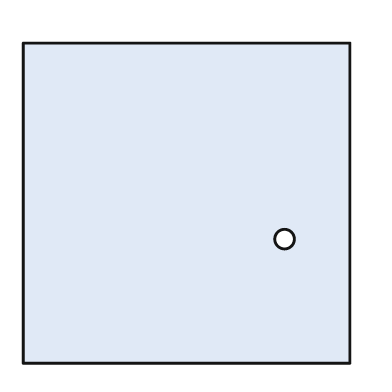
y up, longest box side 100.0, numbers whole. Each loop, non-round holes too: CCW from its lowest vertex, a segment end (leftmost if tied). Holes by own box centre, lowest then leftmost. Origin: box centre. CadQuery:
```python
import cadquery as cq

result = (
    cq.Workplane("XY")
    .moveTo(-50.0, -49.0)
    .lineTo(50.0, -49.0)
    .lineTo(50.0, 49.0)
    .lineTo(-50.0, 49.0)
    .close()
    .moveTo(30.0, -11.0)
    .circle(3.0)
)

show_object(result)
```